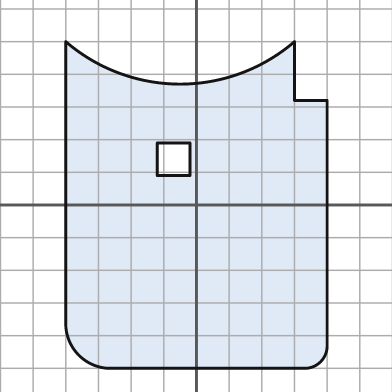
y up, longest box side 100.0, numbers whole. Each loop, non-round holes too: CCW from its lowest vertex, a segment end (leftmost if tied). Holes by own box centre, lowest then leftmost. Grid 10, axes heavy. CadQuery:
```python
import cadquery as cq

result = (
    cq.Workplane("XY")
    .moveTo(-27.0, -50.0)
    .lineTo(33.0, -50.0)
    .threePointArc((38.0, -48.0), (40.0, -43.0))
    .lineTo(40.0, 32.0)
    .lineTo(30.0, 32.0)
    .lineTo(30.0, 50.0)
    .threePointArc((-5.0, 37.0), (-40.0, 50.0))
    .lineTo(-40.0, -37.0)
    .threePointArc((-36.0, -46.0), (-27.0, -50.0))
    .close()
    .moveTo(-12.0, 9.0)
    .lineTo(-2.0, 9.0)
    .lineTo(-2.0, 19.0)
    .lineTo(-12.0, 19.0)
    .close()
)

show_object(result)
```